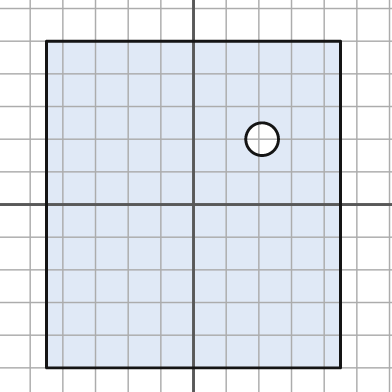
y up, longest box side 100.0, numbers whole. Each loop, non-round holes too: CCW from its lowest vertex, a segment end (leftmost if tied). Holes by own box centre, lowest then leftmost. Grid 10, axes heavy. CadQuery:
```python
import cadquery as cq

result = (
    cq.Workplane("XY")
    .moveTo(-45.0, -50.0)
    .lineTo(45.0, -50.0)
    .lineTo(45.0, 50.0)
    .lineTo(-45.0, 50.0)
    .close()
    .moveTo(21.0, 20.0)
    .circle(5.0)
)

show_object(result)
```